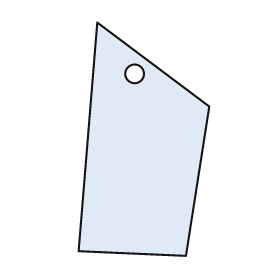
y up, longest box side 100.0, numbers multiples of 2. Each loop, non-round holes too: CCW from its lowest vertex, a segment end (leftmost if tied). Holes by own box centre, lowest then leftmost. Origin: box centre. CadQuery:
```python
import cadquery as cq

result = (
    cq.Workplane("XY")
    .moveTo(18.0, -50.0)
    .lineTo(28.0, 14.0)
    .lineTo(-20.0, 50.0)
    .lineTo(-28.0, -48.0)
    .close()
    .moveTo(-4.0, 28.0)
    .circle(4.0)
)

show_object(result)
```